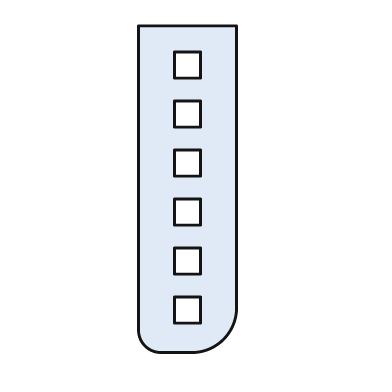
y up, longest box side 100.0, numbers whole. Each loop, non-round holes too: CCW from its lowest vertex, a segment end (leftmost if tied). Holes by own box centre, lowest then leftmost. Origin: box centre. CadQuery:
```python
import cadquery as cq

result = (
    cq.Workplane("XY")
    .moveTo(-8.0, -50.0)
    .lineTo(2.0, -50.0)
    .threePointArc((11.0, -46.0), (15.0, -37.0))
    .lineTo(15.0, 50.0)
    .lineTo(-15.0, 50.0)
    .lineTo(-15.0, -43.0)
    .threePointArc((-13.0, -48.0), (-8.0, -50.0))
    .close()
    .moveTo(-4.0, -41.0)
    .lineTo(4.0, -41.0)
    .lineTo(4.0, -33.0)
    .lineTo(-4.0, -33.0)
    .close()
    .moveTo(-4.0, -26.0)
    .lineTo(4.0, -26.0)
    .lineTo(4.0, -18.0)
    .lineTo(-4.0, -18.0)
    .close()
    .moveTo(-4.0, -11.0)
    .lineTo(4.0, -11.0)
    .lineTo(4.0, -3.0)
    .lineTo(-4.0, -3.0)
    .close()
    .moveTo(-4.0, 4.0)
    .lineTo(4.0, 4.0)
    .lineTo(4.0, 12.0)
    .lineTo(-4.0, 12.0)
    .close()
    .moveTo(-4.0, 19.0)
    .lineTo(4.0, 19.0)
    .lineTo(4.0, 27.0)
    .lineTo(-4.0, 27.0)
    .close()
    .moveTo(-4.0, 34.0)
    .lineTo(4.0, 34.0)
    .lineTo(4.0, 42.0)
    .lineTo(-4.0, 42.0)
    .close()
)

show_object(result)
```